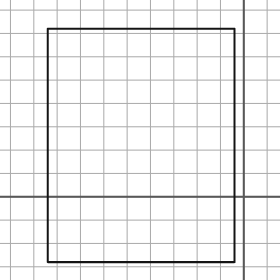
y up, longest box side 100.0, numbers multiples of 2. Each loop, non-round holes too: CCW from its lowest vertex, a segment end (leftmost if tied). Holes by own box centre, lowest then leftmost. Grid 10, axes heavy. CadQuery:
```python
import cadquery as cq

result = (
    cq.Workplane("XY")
    .moveTo(-84.0, -28.0)
    .lineTo(-4.0, -28.0)
    .lineTo(-4.0, 72.0)
    .lineTo(-84.0, 72.0)
    .close()
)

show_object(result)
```